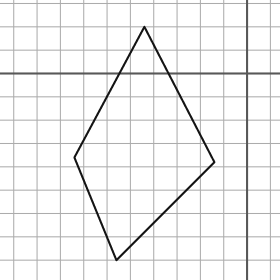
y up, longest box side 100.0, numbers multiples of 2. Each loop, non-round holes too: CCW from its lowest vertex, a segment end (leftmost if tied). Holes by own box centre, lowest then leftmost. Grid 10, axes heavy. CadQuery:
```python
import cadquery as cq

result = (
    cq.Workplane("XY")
    .moveTo(-56.0, -80.0)
    .lineTo(-14.0, -38.0)
    .lineTo(-44.0, 20.0)
    .lineTo(-74.0, -36.0)
    .close()
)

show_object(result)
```